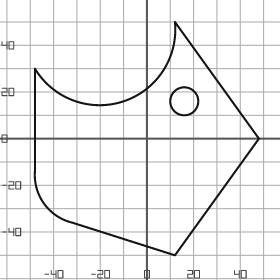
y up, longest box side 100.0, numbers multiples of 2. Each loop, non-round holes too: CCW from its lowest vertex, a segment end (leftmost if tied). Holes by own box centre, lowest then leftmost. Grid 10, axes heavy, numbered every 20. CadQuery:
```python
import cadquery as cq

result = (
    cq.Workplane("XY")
    .moveTo(12.0, -50.0)
    .lineTo(48.0, 0.0)
    .lineTo(12.0, 50.0)
    .threePointArc((-10.0, 16.0), (-48.0, 30.0))
    .lineTo(-48.0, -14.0)
    .threePointArc((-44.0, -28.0), (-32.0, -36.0))
    .close()
    .moveTo(16.0, 16.0)
    .circle(6.0)
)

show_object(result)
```